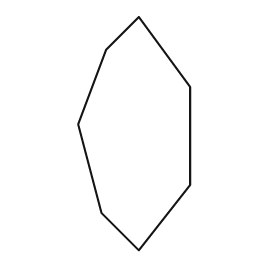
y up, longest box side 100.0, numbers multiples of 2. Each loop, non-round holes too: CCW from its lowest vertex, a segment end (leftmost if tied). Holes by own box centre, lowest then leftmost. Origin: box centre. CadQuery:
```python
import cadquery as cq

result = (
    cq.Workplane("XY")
    .moveTo(2.0, -50.0)
    .lineTo(24.0, -22.0)
    .lineTo(24.0, 20.0)
    .lineTo(2.0, 50.0)
    .lineTo(-12.0, 36.0)
    .lineTo(-24.0, 4.0)
    .lineTo(-14.0, -34.0)
    .close()
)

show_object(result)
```